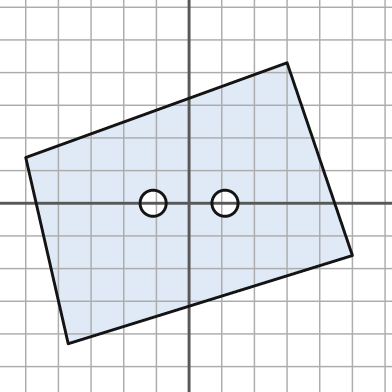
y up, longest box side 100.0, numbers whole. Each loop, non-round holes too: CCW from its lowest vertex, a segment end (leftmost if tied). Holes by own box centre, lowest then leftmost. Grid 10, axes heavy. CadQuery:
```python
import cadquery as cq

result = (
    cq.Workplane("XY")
    .moveTo(-37.0, -43.0)
    .lineTo(50.0, -16.0)
    .lineTo(30.0, 43.0)
    .lineTo(-50.0, 14.0)
    .close()
    .moveTo(-11.0, 0.0)
    .circle(4.0)
    .moveTo(11.0, 0.0)
    .circle(4.0)
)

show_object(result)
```